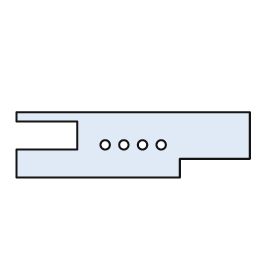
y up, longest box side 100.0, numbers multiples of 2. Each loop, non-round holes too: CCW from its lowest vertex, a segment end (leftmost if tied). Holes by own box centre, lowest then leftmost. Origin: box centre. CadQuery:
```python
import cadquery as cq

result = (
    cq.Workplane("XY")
    .moveTo(-50.0, -14.0)
    .lineTo(20.0, -14.0)
    .lineTo(20.0, -6.0)
    .lineTo(50.0, -6.0)
    .lineTo(50.0, 14.0)
    .lineTo(-50.0, 14.0)
    .lineTo(-50.0, 10.0)
    .lineTo(-24.0, 10.0)
    .lineTo(-24.0, -2.0)
    .lineTo(-50.0, -2.0)
    .close()
    .moveTo(-12.0, 0.0)
    .circle(2.0)
    .moveTo(-4.0, 0.0)
    .circle(2.0)
    .moveTo(4.0, 0.0)
    .circle(2.0)
    .moveTo(12.0, 0.0)
    .circle(2.0)
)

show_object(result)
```